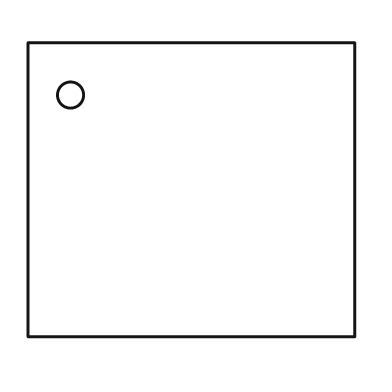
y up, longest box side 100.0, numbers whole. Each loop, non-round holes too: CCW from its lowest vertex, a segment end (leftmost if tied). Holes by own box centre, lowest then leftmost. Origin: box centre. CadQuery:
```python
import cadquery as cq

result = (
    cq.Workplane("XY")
    .moveTo(-50.0, -45.0)
    .lineTo(50.0, -45.0)
    .lineTo(50.0, 45.0)
    .lineTo(-50.0, 45.0)
    .close()
    .moveTo(-37.0, 29.0)
    .circle(4.0)
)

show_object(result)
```